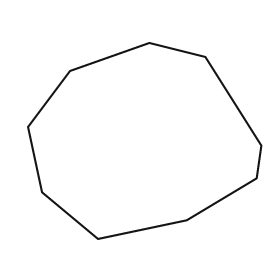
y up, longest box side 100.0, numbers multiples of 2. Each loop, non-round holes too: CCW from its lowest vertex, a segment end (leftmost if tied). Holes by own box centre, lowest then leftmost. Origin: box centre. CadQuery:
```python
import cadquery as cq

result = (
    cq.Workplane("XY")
    .moveTo(-20.0, -42.0)
    .lineTo(18.0, -34.0)
    .lineTo(48.0, -16.0)
    .lineTo(50.0, -2.0)
    .lineTo(26.0, 36.0)
    .lineTo(2.0, 42.0)
    .lineTo(-32.0, 30.0)
    .lineTo(-50.0, 6.0)
    .lineTo(-44.0, -22.0)
    .close()
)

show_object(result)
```